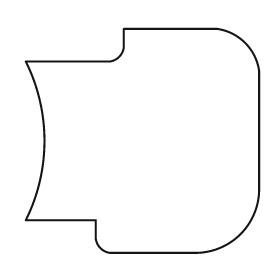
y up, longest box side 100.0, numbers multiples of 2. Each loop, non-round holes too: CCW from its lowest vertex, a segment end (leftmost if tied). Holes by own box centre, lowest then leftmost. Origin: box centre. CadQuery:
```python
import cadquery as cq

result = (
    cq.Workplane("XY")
    .moveTo(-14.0, -48.0)
    .lineTo(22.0, -48.0)
    .threePointArc((42.0, -40.0), (50.0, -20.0))
    .lineTo(50.0, 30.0)
    .threePointArc((44.0, 42.0), (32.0, 48.0))
    .lineTo(-8.0, 48.0)
    .lineTo(-8.0, 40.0)
    .threePointArc((-10.0, 36.0), (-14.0, 34.0))
    .lineTo(-50.0, 34.0)
    .threePointArc((-42.0, 0.0), (-50.0, -34.0))
    .lineTo(-20.0, -34.0)
    .lineTo(-20.0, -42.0)
    .threePointArc((-18.0, -46.0), (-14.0, -48.0))
    .close()
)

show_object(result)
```